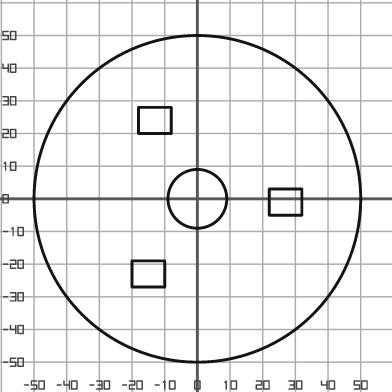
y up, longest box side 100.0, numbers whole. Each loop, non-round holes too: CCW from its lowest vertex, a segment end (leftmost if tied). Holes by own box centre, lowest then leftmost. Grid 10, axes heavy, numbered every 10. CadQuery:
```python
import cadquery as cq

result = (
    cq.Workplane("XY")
    .moveTo(0.0, 0.0)
    .circle(50.0)
    .moveTo(-20.0, -27.0)
    .lineTo(-10.0, -27.0)
    .lineTo(-10.0, -19.0)
    .lineTo(-20.0, -19.0)
    .close()
    .moveTo(22.0, -5.0)
    .lineTo(32.0, -5.0)
    .lineTo(32.0, 3.0)
    .lineTo(22.0, 3.0)
    .close()
    .moveTo(0.0, 0.0)
    .circle(9.0)
    .moveTo(-18.0, 20.0)
    .lineTo(-8.0, 20.0)
    .lineTo(-8.0, 28.0)
    .lineTo(-18.0, 28.0)
    .close()
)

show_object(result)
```